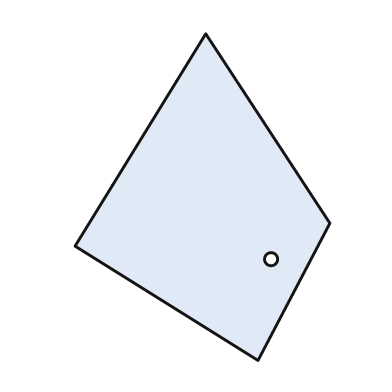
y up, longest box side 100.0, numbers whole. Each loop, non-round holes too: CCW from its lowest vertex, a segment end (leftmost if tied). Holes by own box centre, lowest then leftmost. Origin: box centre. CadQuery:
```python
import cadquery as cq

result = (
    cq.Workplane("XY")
    .moveTo(17.0, -50.0)
    .lineTo(39.0, -8.0)
    .lineTo(1.0, 50.0)
    .lineTo(-39.0, -15.0)
    .close()
    .moveTo(21.0, -19.0)
    .circle(2.0)
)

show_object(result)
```